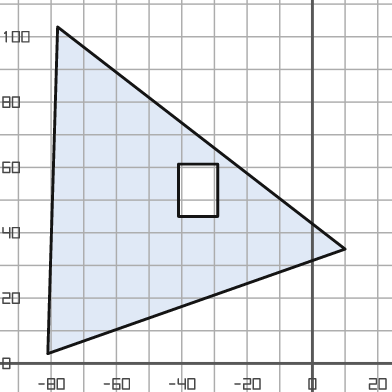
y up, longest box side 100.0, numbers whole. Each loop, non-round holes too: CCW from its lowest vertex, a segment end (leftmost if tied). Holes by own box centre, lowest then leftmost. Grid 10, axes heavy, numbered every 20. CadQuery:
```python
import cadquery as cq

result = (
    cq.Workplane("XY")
    .moveTo(-81.0, 3.0)
    .lineTo(10.0, 35.0)
    .lineTo(-78.0, 103.0)
    .close()
    .moveTo(-41.0, 45.0)
    .lineTo(-29.0, 45.0)
    .lineTo(-29.0, 61.0)
    .lineTo(-41.0, 61.0)
    .close()
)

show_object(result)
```